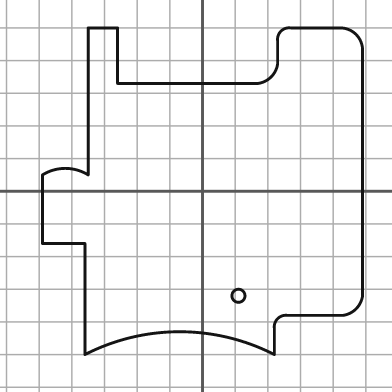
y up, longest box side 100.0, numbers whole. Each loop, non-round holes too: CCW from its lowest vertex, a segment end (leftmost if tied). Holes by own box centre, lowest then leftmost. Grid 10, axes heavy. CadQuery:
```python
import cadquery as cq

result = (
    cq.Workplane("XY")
    .moveTo(-36.0, -50.0)
    .threePointArc((-7.0, -43.0), (22.0, -50.0))
    .lineTo(22.0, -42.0)
    .threePointArc((23.0, -39.0), (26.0, -38.0))
    .lineTo(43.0, -38.0)
    .threePointArc((47.0, -36.0), (49.0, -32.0))
    .lineTo(49.0, 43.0)
    .threePointArc((47.0, 48.0), (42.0, 50.0))
    .lineTo(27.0, 50.0)
    .threePointArc((24.0, 49.0), (23.0, 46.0))
    .lineTo(23.0, 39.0)
    .threePointArc((21.0, 35.0), (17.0, 33.0))
    .lineTo(-26.0, 33.0)
    .lineTo(-26.0, 50.0)
    .lineTo(-35.0, 50.0)
    .lineTo(-35.0, 5.0)
    .threePointArc((-42.0, 7.0), (-49.0, 5.0))
    .lineTo(-49.0, -16.0)
    .lineTo(-36.0, -16.0)
    .close()
    .moveTo(11.0, -32.0)
    .circle(2.0)
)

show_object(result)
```